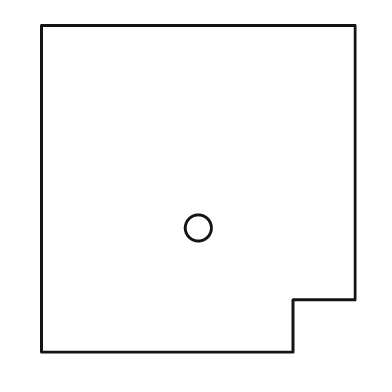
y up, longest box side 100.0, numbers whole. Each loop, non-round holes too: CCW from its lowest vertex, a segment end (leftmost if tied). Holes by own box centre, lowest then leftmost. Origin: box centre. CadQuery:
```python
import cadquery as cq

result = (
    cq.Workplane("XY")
    .moveTo(-48.0, -50.0)
    .lineTo(29.0, -50.0)
    .lineTo(29.0, -34.0)
    .lineTo(48.0, -34.0)
    .lineTo(48.0, 50.0)
    .lineTo(-48.0, 50.0)
    .close()
    .moveTo(0.0, -12.0)
    .circle(4.0)
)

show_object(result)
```